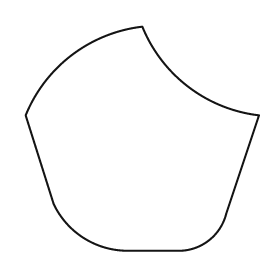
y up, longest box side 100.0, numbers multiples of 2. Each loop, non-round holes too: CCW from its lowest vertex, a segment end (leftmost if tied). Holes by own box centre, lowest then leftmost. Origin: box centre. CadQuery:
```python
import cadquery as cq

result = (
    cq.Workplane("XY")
    .moveTo(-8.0, -48.0)
    .lineTo(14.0, -48.0)
    .threePointArc((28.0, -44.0), (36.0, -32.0))
    .lineTo(50.0, 10.0)
    .threePointArc((20.0, 22.0), (0.0, 48.0))
    .threePointArc((-30.0, 36.0), (-50.0, 10.0))
    .lineTo(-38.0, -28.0)
    .threePointArc((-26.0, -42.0), (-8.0, -48.0))
    .close()
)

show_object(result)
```